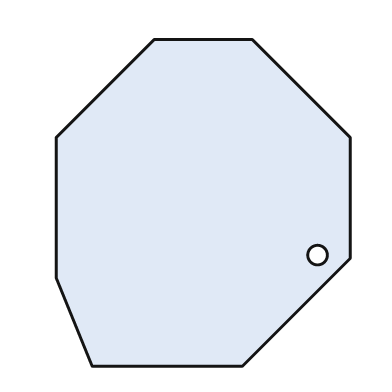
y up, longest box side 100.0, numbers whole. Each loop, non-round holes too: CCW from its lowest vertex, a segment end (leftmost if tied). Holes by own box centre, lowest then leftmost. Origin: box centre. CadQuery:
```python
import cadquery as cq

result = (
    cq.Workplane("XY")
    .moveTo(-34.0, -50.0)
    .lineTo(12.0, -50.0)
    .lineTo(45.0, -17.0)
    .lineTo(45.0, 20.0)
    .lineTo(15.0, 50.0)
    .lineTo(-15.0, 50.0)
    .lineTo(-45.0, 20.0)
    .lineTo(-45.0, -23.0)
    .close()
    .moveTo(35.0, -16.0)
    .circle(3.0)
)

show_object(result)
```